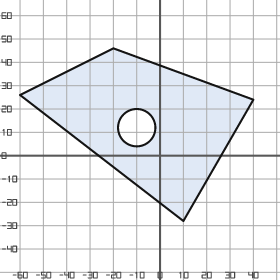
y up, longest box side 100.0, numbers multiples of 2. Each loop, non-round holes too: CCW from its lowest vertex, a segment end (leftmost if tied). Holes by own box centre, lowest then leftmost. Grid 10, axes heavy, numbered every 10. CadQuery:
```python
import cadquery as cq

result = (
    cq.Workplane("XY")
    .moveTo(10.0, -28.0)
    .lineTo(40.0, 24.0)
    .lineTo(-20.0, 46.0)
    .lineTo(-60.0, 26.0)
    .close()
    .moveTo(-10.0, 12.0)
    .circle(8.0)
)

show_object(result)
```